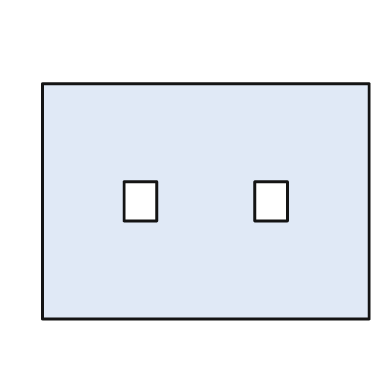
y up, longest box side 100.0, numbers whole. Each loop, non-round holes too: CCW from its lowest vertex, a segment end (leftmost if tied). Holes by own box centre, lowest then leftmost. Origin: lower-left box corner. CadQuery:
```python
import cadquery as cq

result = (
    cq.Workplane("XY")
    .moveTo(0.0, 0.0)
    .lineTo(100.0, 0.0)
    .lineTo(100.0, 72.0)
    .lineTo(0.0, 72.0)
    .close()
    .moveTo(25.0, 30.0)
    .lineTo(35.0, 30.0)
    .lineTo(35.0, 42.0)
    .lineTo(25.0, 42.0)
    .close()
    .moveTo(65.0, 30.0)
    .lineTo(75.0, 30.0)
    .lineTo(75.0, 42.0)
    .lineTo(65.0, 42.0)
    .close()
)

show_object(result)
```